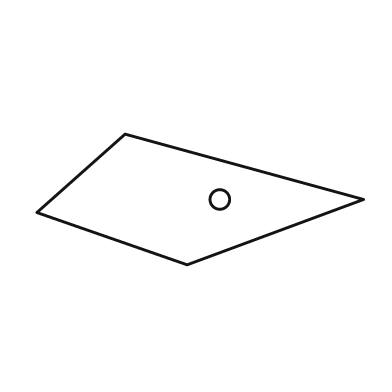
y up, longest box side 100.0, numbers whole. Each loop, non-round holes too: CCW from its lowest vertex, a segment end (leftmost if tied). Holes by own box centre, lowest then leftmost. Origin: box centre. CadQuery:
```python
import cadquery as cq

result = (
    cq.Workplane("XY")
    .moveTo(-4.0, -20.0)
    .lineTo(50.0, 0.0)
    .lineTo(-23.0, 20.0)
    .lineTo(-50.0, -4.0)
    .close()
    .moveTo(6.0, 0.0)
    .circle(3.0)
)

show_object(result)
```